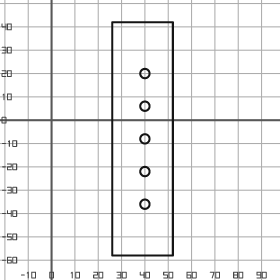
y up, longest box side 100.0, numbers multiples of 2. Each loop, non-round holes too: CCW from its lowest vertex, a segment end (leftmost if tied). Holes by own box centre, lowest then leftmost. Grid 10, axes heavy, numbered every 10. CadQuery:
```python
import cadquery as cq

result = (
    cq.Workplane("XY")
    .moveTo(26.0, -58.0)
    .lineTo(52.0, -58.0)
    .lineTo(52.0, 42.0)
    .lineTo(26.0, 42.0)
    .close()
    .moveTo(40.0, -36.0)
    .circle(2.0)
    .moveTo(40.0, -22.0)
    .circle(2.0)
    .moveTo(40.0, -8.0)
    .circle(2.0)
    .moveTo(40.0, 6.0)
    .circle(2.0)
    .moveTo(40.0, 20.0)
    .circle(2.0)
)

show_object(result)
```